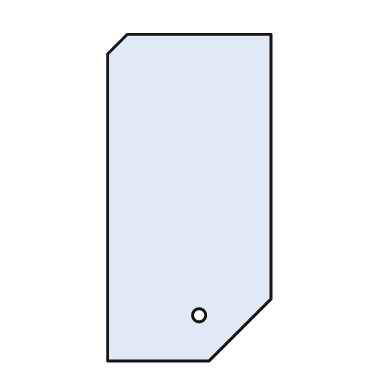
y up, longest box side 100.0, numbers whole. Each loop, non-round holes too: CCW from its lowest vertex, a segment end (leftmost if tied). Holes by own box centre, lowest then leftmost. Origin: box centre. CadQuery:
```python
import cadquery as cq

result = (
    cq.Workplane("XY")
    .moveTo(-25.0, -50.0)
    .lineTo(6.0, -50.0)
    .lineTo(25.0, -31.0)
    .lineTo(25.0, 50.0)
    .lineTo(-19.0, 50.0)
    .lineTo(-25.0, 44.0)
    .close()
    .moveTo(3.0, -36.0)
    .circle(2.0)
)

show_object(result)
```